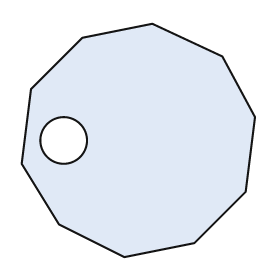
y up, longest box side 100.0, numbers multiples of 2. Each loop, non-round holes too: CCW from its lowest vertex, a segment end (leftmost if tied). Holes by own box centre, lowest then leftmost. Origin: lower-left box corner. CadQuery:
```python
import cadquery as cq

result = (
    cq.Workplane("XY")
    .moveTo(44.0, 0.0)
    .lineTo(74.0, 6.0)
    .lineTo(96.0, 28.0)
    .lineTo(100.0, 60.0)
    .lineTo(86.0, 86.0)
    .lineTo(56.0, 100.0)
    .lineTo(26.0, 94.0)
    .lineTo(4.0, 72.0)
    .lineTo(0.0, 40.0)
    .lineTo(16.0, 14.0)
    .close()
    .moveTo(18.0, 50.0)
    .circle(10.0)
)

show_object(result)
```